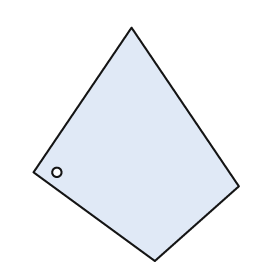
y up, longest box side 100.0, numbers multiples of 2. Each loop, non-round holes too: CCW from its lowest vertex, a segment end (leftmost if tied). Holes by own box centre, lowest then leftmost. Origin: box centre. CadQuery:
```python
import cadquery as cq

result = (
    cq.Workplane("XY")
    .moveTo(8.0, -50.0)
    .lineTo(44.0, -18.0)
    .lineTo(-2.0, 50.0)
    .lineTo(-44.0, -12.0)
    .close()
    .moveTo(-34.0, -12.0)
    .circle(2.0)
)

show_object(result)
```